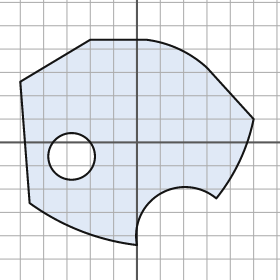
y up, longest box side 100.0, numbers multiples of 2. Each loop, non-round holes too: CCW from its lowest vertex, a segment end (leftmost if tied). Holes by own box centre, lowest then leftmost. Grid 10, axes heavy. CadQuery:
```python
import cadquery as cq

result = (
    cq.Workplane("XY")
    .moveTo(0.0, -44.0)
    .threePointArc((10.0, -22.0), (34.0, -24.0))
    .threePointArc((44.0, -8.0), (50.0, 10.0))
    .lineTo(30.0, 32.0)
    .threePointArc((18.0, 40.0), (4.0, 44.0))
    .lineTo(-20.0, 44.0)
    .lineTo(-50.0, 26.0)
    .lineTo(-46.0, -26.0)
    .threePointArc((-24.0, -38.0), (0.0, -44.0))
    .close()
    .moveTo(-28.0, -6.0)
    .circle(10.0)
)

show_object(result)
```